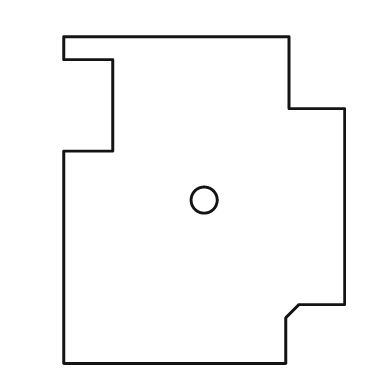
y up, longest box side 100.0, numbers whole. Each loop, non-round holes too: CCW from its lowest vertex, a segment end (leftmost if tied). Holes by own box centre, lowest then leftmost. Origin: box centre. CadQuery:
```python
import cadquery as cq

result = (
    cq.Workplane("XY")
    .moveTo(-43.0, -50.0)
    .lineTo(25.0, -50.0)
    .lineTo(25.0, -36.0)
    .lineTo(29.0, -32.0)
    .lineTo(43.0, -32.0)
    .lineTo(43.0, 28.0)
    .lineTo(26.0, 28.0)
    .lineTo(26.0, 50.0)
    .lineTo(-43.0, 50.0)
    .lineTo(-43.0, 43.0)
    .lineTo(-28.0, 43.0)
    .lineTo(-28.0, 15.0)
    .lineTo(-43.0, 15.0)
    .close()
    .moveTo(0.0, 0.0)
    .circle(4.0)
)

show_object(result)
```